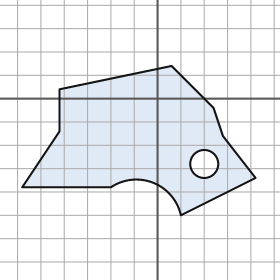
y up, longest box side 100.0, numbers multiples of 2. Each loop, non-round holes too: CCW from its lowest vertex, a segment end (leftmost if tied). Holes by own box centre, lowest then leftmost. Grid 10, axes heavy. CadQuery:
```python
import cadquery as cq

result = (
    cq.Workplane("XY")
    .moveTo(10.0, -50.0)
    .lineTo(42.0, -34.0)
    .lineTo(28.0, -16.0)
    .lineTo(24.0, -4.0)
    .lineTo(6.0, 14.0)
    .lineTo(-42.0, 4.0)
    .lineTo(-42.0, -14.0)
    .lineTo(-58.0, -38.0)
    .lineTo(-20.0, -38.0)
    .threePointArc((-2.0, -36.0), (10.0, -50.0))
    .close()
    .moveTo(20.0, -28.0)
    .circle(6.0)
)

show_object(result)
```